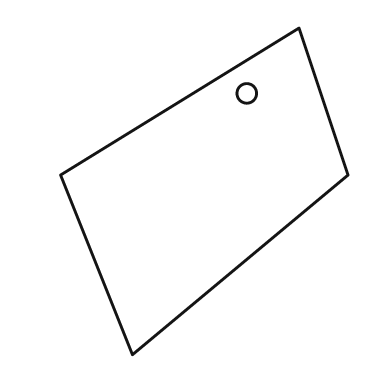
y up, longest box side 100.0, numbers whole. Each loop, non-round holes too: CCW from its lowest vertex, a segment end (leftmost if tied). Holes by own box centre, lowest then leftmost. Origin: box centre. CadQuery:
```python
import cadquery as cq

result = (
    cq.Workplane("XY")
    .moveTo(-22.0, -50.0)
    .lineTo(44.0, 5.0)
    .lineTo(29.0, 50.0)
    .lineTo(-44.0, 5.0)
    .close()
    .moveTo(13.0, 30.0)
    .circle(3.0)
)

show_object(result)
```